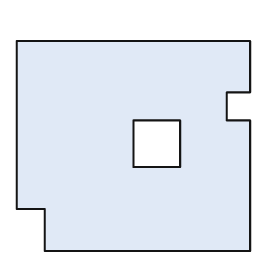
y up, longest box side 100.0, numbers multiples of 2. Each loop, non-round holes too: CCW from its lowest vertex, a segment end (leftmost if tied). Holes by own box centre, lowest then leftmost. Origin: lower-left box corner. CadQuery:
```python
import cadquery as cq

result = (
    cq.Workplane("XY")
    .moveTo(12.0, 0.0)
    .lineTo(100.0, 0.0)
    .lineTo(100.0, 56.0)
    .lineTo(90.0, 56.0)
    .lineTo(90.0, 68.0)
    .lineTo(100.0, 68.0)
    .lineTo(100.0, 90.0)
    .lineTo(0.0, 90.0)
    .lineTo(0.0, 18.0)
    .lineTo(12.0, 18.0)
    .close()
    .moveTo(50.0, 36.0)
    .lineTo(70.0, 36.0)
    .lineTo(70.0, 56.0)
    .lineTo(50.0, 56.0)
    .close()
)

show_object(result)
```